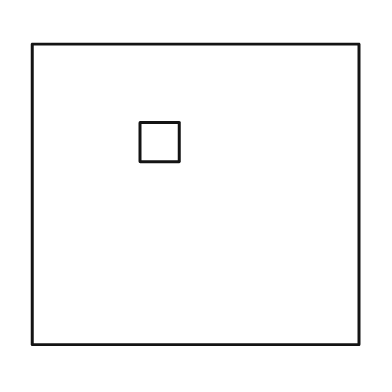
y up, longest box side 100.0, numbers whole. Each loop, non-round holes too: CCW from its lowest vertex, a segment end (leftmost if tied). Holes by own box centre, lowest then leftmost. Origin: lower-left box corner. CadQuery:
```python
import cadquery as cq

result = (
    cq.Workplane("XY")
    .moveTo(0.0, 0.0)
    .lineTo(100.0, 0.0)
    .lineTo(100.0, 92.0)
    .lineTo(0.0, 92.0)
    .close()
    .moveTo(33.0, 56.0)
    .lineTo(45.0, 56.0)
    .lineTo(45.0, 68.0)
    .lineTo(33.0, 68.0)
    .close()
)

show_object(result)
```